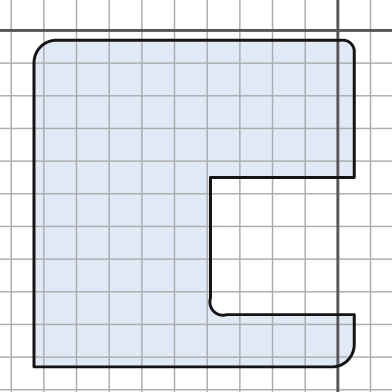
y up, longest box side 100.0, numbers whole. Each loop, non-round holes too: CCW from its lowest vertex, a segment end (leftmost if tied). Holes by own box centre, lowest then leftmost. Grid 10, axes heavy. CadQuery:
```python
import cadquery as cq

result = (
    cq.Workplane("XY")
    .moveTo(-93.0, -103.0)
    .lineTo(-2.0, -103.0)
    .threePointArc((3.0, -101.0), (5.0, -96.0))
    .lineTo(5.0, -87.0)
    .lineTo(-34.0, -87.0)
    .threePointArc((-38.0, -86.0), (-39.0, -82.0))
    .lineTo(-39.0, -45.0)
    .lineTo(5.0, -45.0)
    .lineTo(5.0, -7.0)
    .threePointArc((4.0, -4.0), (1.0, -3.0))
    .lineTo(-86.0, -3.0)
    .threePointArc((-91.0, -5.0), (-93.0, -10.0))
    .close()
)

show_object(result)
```